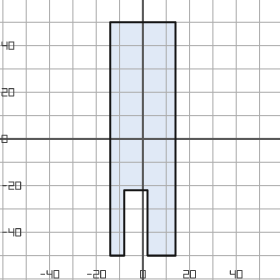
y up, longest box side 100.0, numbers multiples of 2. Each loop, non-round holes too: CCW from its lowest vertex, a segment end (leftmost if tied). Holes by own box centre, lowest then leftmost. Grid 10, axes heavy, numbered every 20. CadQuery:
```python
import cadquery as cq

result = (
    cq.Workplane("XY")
    .moveTo(-14.0, -50.0)
    .lineTo(-8.0, -50.0)
    .lineTo(-8.0, -22.0)
    .lineTo(2.0, -22.0)
    .lineTo(2.0, -50.0)
    .lineTo(14.0, -50.0)
    .lineTo(14.0, 50.0)
    .lineTo(-14.0, 50.0)
    .close()
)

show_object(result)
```